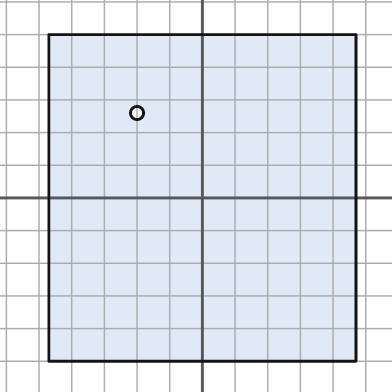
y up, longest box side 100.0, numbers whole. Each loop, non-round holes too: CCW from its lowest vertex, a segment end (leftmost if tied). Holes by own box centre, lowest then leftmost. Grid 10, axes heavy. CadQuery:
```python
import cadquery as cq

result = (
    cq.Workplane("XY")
    .moveTo(-47.0, -50.0)
    .lineTo(47.0, -50.0)
    .lineTo(47.0, 50.0)
    .lineTo(-47.0, 50.0)
    .close()
    .moveTo(-20.0, 26.0)
    .circle(2.0)
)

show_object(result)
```